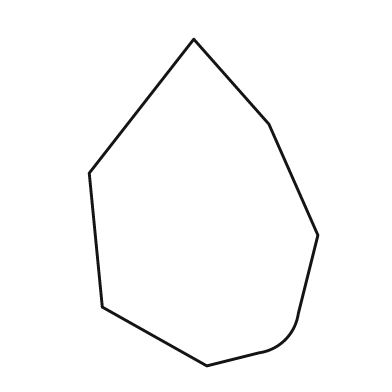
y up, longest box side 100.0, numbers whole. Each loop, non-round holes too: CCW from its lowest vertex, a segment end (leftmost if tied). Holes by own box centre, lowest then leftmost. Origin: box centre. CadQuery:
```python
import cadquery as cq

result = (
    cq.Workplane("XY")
    .moveTo(1.0, -50.0)
    .lineTo(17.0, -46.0)
    .threePointArc((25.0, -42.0), (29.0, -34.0))
    .lineTo(35.0, -10.0)
    .lineTo(20.0, 24.0)
    .lineTo(-3.0, 50.0)
    .lineTo(-35.0, 9.0)
    .lineTo(-31.0, -32.0)
    .close()
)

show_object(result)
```